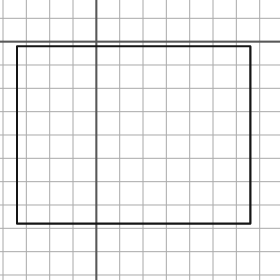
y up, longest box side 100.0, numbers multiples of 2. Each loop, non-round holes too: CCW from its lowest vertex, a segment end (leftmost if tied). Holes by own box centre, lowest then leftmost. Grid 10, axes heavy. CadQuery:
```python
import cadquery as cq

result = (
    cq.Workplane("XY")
    .moveTo(-34.0, -78.0)
    .lineTo(66.0, -78.0)
    .lineTo(66.0, -2.0)
    .lineTo(-34.0, -2.0)
    .close()
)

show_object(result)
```